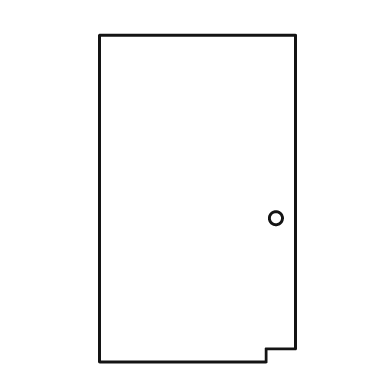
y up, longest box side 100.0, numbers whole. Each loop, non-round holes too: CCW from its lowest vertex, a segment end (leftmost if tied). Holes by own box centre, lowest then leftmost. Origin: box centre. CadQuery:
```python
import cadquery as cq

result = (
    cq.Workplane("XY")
    .moveTo(-30.0, -50.0)
    .lineTo(21.0, -50.0)
    .lineTo(21.0, -46.0)
    .lineTo(30.0, -46.0)
    .lineTo(30.0, 50.0)
    .lineTo(-30.0, 50.0)
    .close()
    .moveTo(24.0, -6.0)
    .circle(2.0)
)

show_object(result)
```